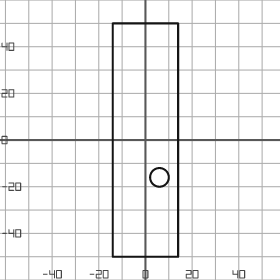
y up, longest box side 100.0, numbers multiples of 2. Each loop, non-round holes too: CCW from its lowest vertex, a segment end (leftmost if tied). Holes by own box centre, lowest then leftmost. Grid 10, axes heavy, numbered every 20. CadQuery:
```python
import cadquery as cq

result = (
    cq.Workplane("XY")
    .moveTo(-14.0, -50.0)
    .lineTo(14.0, -50.0)
    .lineTo(14.0, 50.0)
    .lineTo(-14.0, 50.0)
    .close()
    .moveTo(6.0, -16.0)
    .circle(4.0)
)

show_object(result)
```